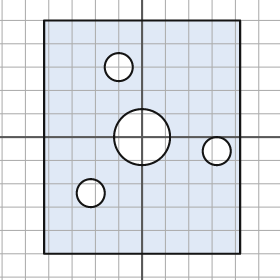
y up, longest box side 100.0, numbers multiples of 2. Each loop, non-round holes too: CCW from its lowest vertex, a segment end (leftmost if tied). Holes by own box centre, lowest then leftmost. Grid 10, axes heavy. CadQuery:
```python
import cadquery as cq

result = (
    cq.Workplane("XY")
    .moveTo(-42.0, -50.0)
    .lineTo(42.0, -50.0)
    .lineTo(42.0, 50.0)
    .lineTo(-42.0, 50.0)
    .close()
    .moveTo(-22.0, -24.0)
    .circle(6.0)
    .moveTo(32.0, -6.0)
    .circle(6.0)
    .moveTo(0.0, 0.0)
    .circle(12.0)
    .moveTo(-10.0, 30.0)
    .circle(6.0)
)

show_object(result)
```